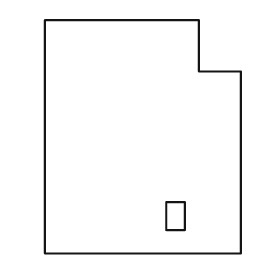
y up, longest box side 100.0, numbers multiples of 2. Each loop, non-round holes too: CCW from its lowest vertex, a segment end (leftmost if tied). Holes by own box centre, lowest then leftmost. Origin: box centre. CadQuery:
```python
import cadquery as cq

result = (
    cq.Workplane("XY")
    .moveTo(-42.0, -50.0)
    .lineTo(42.0, -50.0)
    .lineTo(42.0, 28.0)
    .lineTo(24.0, 28.0)
    .lineTo(24.0, 50.0)
    .lineTo(-42.0, 50.0)
    .close()
    .moveTo(10.0, -40.0)
    .lineTo(18.0, -40.0)
    .lineTo(18.0, -28.0)
    .lineTo(10.0, -28.0)
    .close()
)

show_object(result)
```